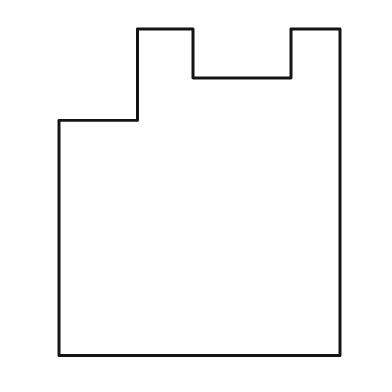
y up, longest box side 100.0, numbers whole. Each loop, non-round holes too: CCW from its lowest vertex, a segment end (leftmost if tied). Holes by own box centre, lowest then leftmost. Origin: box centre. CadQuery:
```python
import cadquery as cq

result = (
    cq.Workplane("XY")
    .moveTo(-43.0, -50.0)
    .lineTo(43.0, -50.0)
    .lineTo(43.0, 50.0)
    .lineTo(28.0, 50.0)
    .lineTo(28.0, 35.0)
    .lineTo(-2.0, 35.0)
    .lineTo(-2.0, 50.0)
    .lineTo(-19.0, 50.0)
    .lineTo(-19.0, 22.0)
    .lineTo(-43.0, 22.0)
    .close()
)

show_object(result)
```